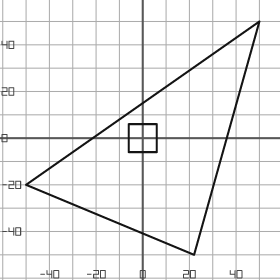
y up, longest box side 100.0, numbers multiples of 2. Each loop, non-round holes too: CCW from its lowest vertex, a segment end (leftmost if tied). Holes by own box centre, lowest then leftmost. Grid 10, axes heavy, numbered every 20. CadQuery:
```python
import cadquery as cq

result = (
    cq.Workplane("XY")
    .moveTo(22.0, -50.0)
    .lineTo(50.0, 50.0)
    .lineTo(-50.0, -20.0)
    .close()
    .moveTo(-6.0, -6.0)
    .lineTo(6.0, -6.0)
    .lineTo(6.0, 6.0)
    .lineTo(-6.0, 6.0)
    .close()
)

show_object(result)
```